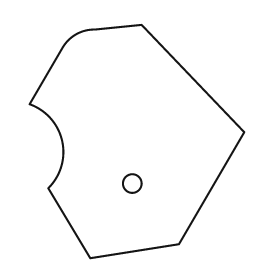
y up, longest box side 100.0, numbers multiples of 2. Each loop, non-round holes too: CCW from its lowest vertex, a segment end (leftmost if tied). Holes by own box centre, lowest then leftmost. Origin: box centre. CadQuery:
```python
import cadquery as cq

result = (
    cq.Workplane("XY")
    .moveTo(-20.0, -50.0)
    .lineTo(18.0, -44.0)
    .lineTo(46.0, 4.0)
    .lineTo(2.0, 50.0)
    .lineTo(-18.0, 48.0)
    .threePointArc((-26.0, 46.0), (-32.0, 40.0))
    .lineTo(-46.0, 16.0)
    .threePointArc((-32.0, 0.0), (-38.0, -20.0))
    .close()
    .moveTo(-2.0, -18.0)
    .circle(4.0)
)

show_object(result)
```